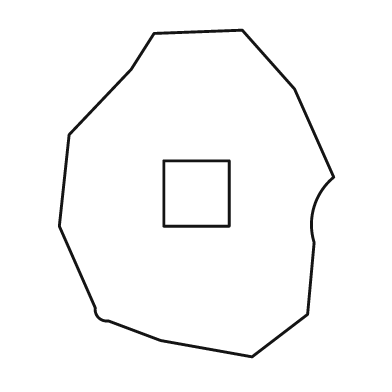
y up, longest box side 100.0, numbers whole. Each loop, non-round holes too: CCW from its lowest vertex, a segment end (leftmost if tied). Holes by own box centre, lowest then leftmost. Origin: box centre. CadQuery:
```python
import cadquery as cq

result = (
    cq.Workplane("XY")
    .moveTo(17.0, -50.0)
    .lineTo(34.0, -37.0)
    .lineTo(36.0, -15.0)
    .threePointArc((36.0, -4.0), (42.0, 5.0))
    .lineTo(30.0, 32.0)
    .lineTo(14.0, 50.0)
    .lineTo(-13.0, 49.0)
    .lineTo(-20.0, 38.0)
    .lineTo(-39.0, 18.0)
    .lineTo(-42.0, -10.0)
    .lineTo(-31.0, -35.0)
    .threePointArc((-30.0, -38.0), (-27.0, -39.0))
    .lineTo(-11.0, -45.0)
    .close()
    .moveTo(-10.0, -10.0)
    .lineTo(10.0, -10.0)
    .lineTo(10.0, 10.0)
    .lineTo(-10.0, 10.0)
    .close()
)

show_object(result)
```